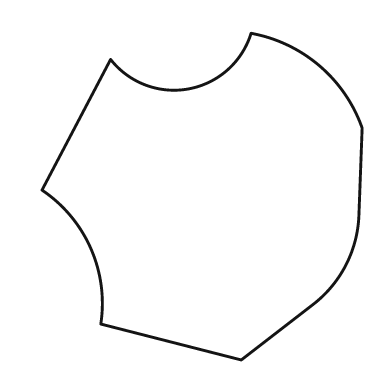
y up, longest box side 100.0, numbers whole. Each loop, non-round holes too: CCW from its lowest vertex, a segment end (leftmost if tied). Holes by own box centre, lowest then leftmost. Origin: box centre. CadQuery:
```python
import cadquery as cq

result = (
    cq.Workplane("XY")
    .moveTo(12.0, -50.0)
    .lineTo(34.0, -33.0)
    .threePointArc((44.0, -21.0), (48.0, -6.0))
    .lineTo(49.0, 21.0)
    .threePointArc((36.0, 40.0), (15.0, 50.0))
    .threePointArc((-4.0, 33.0), (-28.0, 42.0))
    .lineTo(-49.0, 2.0)
    .threePointArc((-34.0, -16.0), (-31.0, -39.0))
    .close()
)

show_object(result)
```